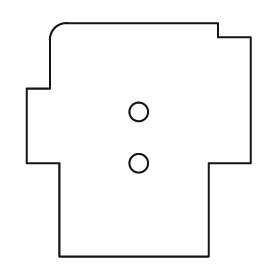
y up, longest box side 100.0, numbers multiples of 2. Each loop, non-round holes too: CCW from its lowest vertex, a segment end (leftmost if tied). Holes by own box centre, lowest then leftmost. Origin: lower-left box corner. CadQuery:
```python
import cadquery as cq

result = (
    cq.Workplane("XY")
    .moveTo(14.0, 0.0)
    .lineTo(78.0, 0.0)
    .lineTo(78.0, 40.0)
    .lineTo(96.0, 40.0)
    .lineTo(96.0, 94.0)
    .lineTo(82.0, 94.0)
    .lineTo(82.0, 100.0)
    .lineTo(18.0, 100.0)
    .threePointArc((12.0, 98.0), (10.0, 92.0))
    .lineTo(10.0, 72.0)
    .lineTo(0.0, 72.0)
    .lineTo(0.0, 40.0)
    .lineTo(14.0, 40.0)
    .close()
    .moveTo(48.0, 40.0)
    .circle(4.0)
    .moveTo(48.0, 62.0)
    .circle(4.0)
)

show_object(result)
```